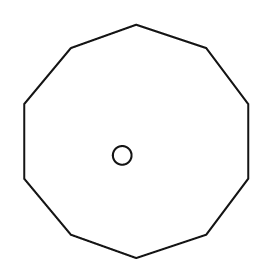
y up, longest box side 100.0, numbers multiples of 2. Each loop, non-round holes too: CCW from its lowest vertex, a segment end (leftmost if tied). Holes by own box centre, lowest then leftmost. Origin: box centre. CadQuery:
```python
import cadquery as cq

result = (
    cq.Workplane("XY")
    .moveTo(0.0, -50.0)
    .lineTo(30.0, -40.0)
    .lineTo(48.0, -16.0)
    .lineTo(48.0, 16.0)
    .lineTo(30.0, 40.0)
    .lineTo(0.0, 50.0)
    .lineTo(-28.0, 40.0)
    .lineTo(-48.0, 16.0)
    .lineTo(-48.0, -16.0)
    .lineTo(-28.0, -40.0)
    .close()
    .moveTo(-6.0, -6.0)
    .circle(4.0)
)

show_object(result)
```